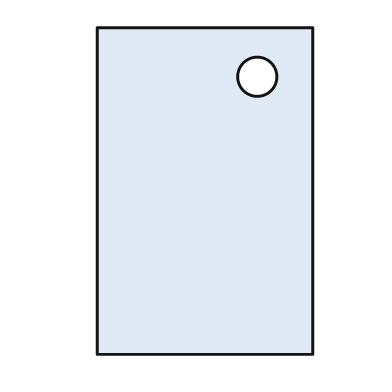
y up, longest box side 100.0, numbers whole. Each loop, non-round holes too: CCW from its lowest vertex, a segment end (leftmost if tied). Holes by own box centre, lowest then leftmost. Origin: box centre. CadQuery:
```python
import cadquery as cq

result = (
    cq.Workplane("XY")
    .moveTo(-33.0, -50.0)
    .lineTo(33.0, -50.0)
    .lineTo(33.0, 50.0)
    .lineTo(-33.0, 50.0)
    .close()
    .moveTo(16.0, 35.0)
    .circle(6.0)
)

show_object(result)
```